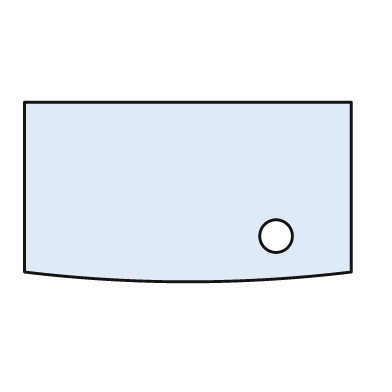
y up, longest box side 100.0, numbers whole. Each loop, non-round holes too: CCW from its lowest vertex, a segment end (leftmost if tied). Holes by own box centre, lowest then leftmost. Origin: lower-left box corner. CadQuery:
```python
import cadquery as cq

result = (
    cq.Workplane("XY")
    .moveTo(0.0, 3.0)
    .threePointArc((50.0, 0.0), (100.0, 3.0))
    .lineTo(100.0, 55.0)
    .lineTo(0.0, 55.0)
    .close()
    .moveTo(77.0, 14.0)
    .circle(5.0)
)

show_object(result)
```